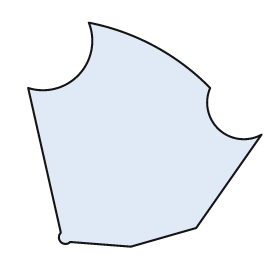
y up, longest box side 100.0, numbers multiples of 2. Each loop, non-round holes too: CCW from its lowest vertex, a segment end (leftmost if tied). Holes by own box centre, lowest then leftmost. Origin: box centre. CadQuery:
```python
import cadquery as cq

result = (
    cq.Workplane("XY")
    .moveTo(-6.0, -48.0)
    .lineTo(22.0, -40.0)
    .lineTo(50.0, 0.0)
    .threePointArc((32.0, 2.0), (28.0, 20.0))
    .threePointArc((4.0, 38.0), (-24.0, 48.0))
    .threePointArc((-28.0, 26.0), (-50.0, 20.0))
    .lineTo(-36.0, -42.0)
    .threePointArc((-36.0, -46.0), (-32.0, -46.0))
    .close()
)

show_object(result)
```